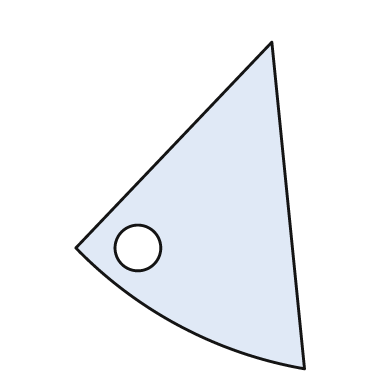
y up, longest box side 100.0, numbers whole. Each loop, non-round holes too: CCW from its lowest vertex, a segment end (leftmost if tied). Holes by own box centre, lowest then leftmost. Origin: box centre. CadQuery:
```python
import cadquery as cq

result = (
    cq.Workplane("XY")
    .moveTo(35.0, -50.0)
    .lineTo(25.0, 50.0)
    .lineTo(-35.0, -13.0)
    .threePointArc((-3.0, -37.0), (35.0, -50.0))
    .close()
    .moveTo(-16.0, -13.0)
    .circle(7.0)
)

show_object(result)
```